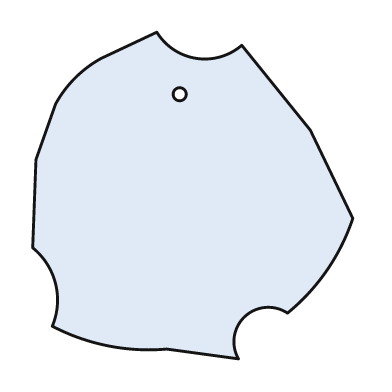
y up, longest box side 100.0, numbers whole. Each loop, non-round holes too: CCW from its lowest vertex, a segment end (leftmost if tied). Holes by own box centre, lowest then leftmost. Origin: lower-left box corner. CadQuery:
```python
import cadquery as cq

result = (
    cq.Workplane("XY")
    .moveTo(63.0, 0.0)
    .threePointArc((65.0, 13.0), (78.0, 14.0))
    .threePointArc((90.0, 27.0), (98.0, 43.0))
    .lineTo(85.0, 70.0)
    .lineTo(64.0, 96.0)
    .threePointArc((50.0, 92.0), (38.0, 100.0))
    .lineTo(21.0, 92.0)
    .threePointArc((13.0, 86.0), (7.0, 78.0))
    .lineTo(1.0, 61.0)
    .lineTo(0.0, 34.0)
    .threePointArc((7.0, 23.0), (6.0, 10.0))
    .threePointArc((23.0, 4.0), (41.0, 3.0))
    .close()
    .moveTo(45.0, 81.0)
    .circle(2.0)
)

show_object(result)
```